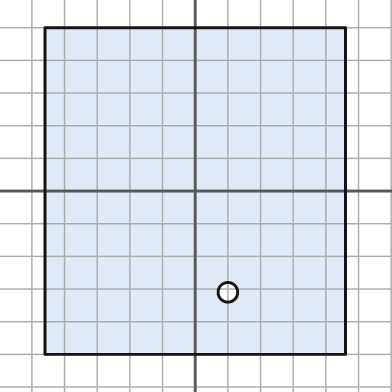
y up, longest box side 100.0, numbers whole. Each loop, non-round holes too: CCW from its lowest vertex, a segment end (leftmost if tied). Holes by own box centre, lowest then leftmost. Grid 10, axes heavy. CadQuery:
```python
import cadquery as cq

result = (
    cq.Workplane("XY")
    .moveTo(-46.0, -50.0)
    .lineTo(46.0, -50.0)
    .lineTo(46.0, 50.0)
    .lineTo(-46.0, 50.0)
    .close()
    .moveTo(10.0, -31.0)
    .circle(3.0)
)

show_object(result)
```